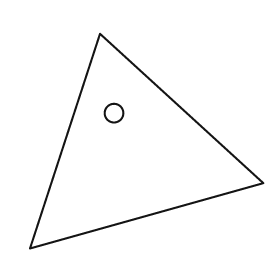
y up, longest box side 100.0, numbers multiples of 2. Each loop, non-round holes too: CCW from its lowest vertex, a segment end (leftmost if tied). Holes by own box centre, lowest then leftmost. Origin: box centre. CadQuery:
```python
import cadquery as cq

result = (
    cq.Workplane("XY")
    .moveTo(-50.0, -46.0)
    .lineTo(50.0, -18.0)
    .lineTo(-20.0, 46.0)
    .close()
    .moveTo(-14.0, 12.0)
    .circle(4.0)
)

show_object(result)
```